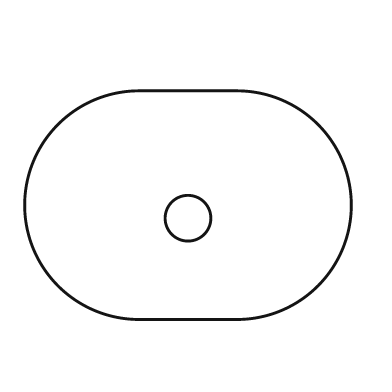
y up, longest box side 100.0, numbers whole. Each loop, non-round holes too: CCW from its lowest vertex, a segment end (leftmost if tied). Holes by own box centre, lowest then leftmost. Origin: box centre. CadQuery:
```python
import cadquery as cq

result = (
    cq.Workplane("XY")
    .moveTo(-15.0, -35.0)
    .lineTo(15.0, -35.0)
    .threePointArc((50.0, 0.0), (15.0, 35.0))
    .lineTo(-15.0, 35.0)
    .threePointArc((-50.0, 0.0), (-15.0, -35.0))
    .close()
    .moveTo(0.0, -4.0)
    .circle(7.0)
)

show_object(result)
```